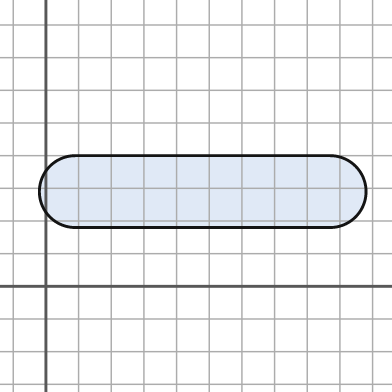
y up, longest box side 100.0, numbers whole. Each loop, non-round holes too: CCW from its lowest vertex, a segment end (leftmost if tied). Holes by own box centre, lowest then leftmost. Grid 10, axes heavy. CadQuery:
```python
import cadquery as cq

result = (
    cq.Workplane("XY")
    .moveTo(9.0, 18.0)
    .lineTo(87.0, 18.0)
    .threePointArc((98.0, 29.0), (87.0, 40.0))
    .lineTo(9.0, 40.0)
    .threePointArc((-2.0, 29.0), (9.0, 18.0))
    .close()
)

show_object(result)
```